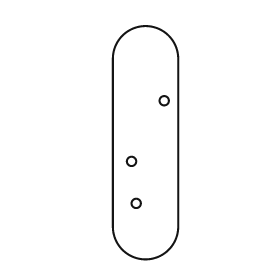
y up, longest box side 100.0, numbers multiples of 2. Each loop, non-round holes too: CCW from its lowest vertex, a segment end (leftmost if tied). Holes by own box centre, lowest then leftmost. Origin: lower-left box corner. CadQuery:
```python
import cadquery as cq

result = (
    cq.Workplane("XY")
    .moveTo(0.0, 14.0)
    .threePointArc((14.0, 0.0), (28.0, 14.0))
    .lineTo(28.0, 86.0)
    .threePointArc((14.0, 100.0), (0.0, 86.0))
    .close()
    .moveTo(10.0, 24.0)
    .circle(2.0)
    .moveTo(8.0, 42.0)
    .circle(2.0)
    .moveTo(22.0, 68.0)
    .circle(2.0)
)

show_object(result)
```